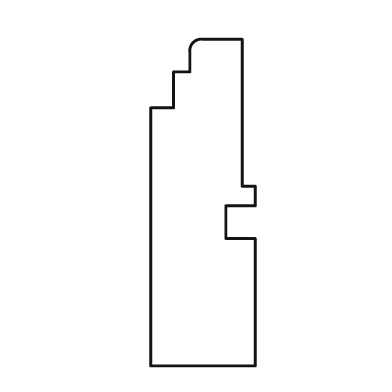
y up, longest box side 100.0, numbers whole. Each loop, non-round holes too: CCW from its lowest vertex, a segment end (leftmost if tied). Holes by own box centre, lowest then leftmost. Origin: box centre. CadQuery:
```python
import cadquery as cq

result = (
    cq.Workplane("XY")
    .moveTo(-16.0, -50.0)
    .lineTo(16.0, -50.0)
    .lineTo(16.0, -11.0)
    .lineTo(7.0, -11.0)
    .lineTo(7.0, -1.0)
    .lineTo(16.0, -1.0)
    .lineTo(16.0, 5.0)
    .lineTo(12.0, 5.0)
    .lineTo(12.0, 50.0)
    .lineTo(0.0, 50.0)
    .threePointArc((-3.0, 49.0), (-4.0, 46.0))
    .lineTo(-4.0, 40.0)
    .lineTo(-9.0, 40.0)
    .lineTo(-9.0, 29.0)
    .lineTo(-16.0, 29.0)
    .close()
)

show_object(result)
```